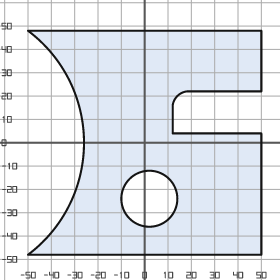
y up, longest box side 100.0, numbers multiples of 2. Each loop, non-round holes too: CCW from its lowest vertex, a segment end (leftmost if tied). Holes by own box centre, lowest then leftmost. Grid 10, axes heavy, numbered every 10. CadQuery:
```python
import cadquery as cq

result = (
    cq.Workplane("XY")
    .moveTo(-50.0, -48.0)
    .lineTo(50.0, -48.0)
    .lineTo(50.0, 4.0)
    .lineTo(12.0, 4.0)
    .lineTo(12.0, 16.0)
    .threePointArc((14.0, 20.0), (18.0, 22.0))
    .lineTo(50.0, 22.0)
    .lineTo(50.0, 48.0)
    .lineTo(-50.0, 48.0)
    .threePointArc((-26.0, 0.0), (-50.0, -48.0))
    .close()
    .moveTo(2.0, -24.0)
    .circle(12.0)
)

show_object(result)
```